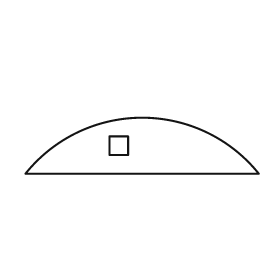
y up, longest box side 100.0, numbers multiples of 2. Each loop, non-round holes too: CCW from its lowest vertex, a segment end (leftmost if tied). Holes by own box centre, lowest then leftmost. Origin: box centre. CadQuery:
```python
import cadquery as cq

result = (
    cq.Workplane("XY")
    .moveTo(-50.0, -12.0)
    .lineTo(50.0, -12.0)
    .threePointArc((0.0, 12.0), (-50.0, -12.0))
    .close()
    .moveTo(-14.0, -4.0)
    .lineTo(-6.0, -4.0)
    .lineTo(-6.0, 4.0)
    .lineTo(-14.0, 4.0)
    .close()
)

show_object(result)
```